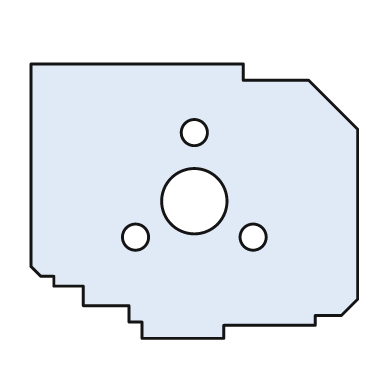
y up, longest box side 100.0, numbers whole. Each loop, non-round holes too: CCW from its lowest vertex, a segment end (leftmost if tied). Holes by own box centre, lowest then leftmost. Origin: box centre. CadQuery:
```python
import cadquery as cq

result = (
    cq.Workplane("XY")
    .moveTo(-16.0, -42.0)
    .lineTo(9.0, -42.0)
    .lineTo(9.0, -38.0)
    .lineTo(37.0, -38.0)
    .lineTo(37.0, -35.0)
    .lineTo(45.0, -35.0)
    .lineTo(50.0, -30.0)
    .lineTo(50.0, 22.0)
    .lineTo(35.0, 37.0)
    .lineTo(15.0, 37.0)
    .lineTo(15.0, 42.0)
    .lineTo(-50.0, 42.0)
    .lineTo(-50.0, -20.0)
    .lineTo(-47.0, -23.0)
    .lineTo(-43.0, -23.0)
    .lineTo(-43.0, -26.0)
    .lineTo(-34.0, -26.0)
    .lineTo(-34.0, -32.0)
    .lineTo(-20.0, -32.0)
    .lineTo(-20.0, -37.0)
    .lineTo(-16.0, -37.0)
    .close()
    .moveTo(-18.0, -11.0)
    .circle(4.0)
    .moveTo(18.0, -11.0)
    .circle(4.0)
    .moveTo(0.0, 0.0)
    .circle(10.0)
    .moveTo(0.0, 21.0)
    .circle(4.0)
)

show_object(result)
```